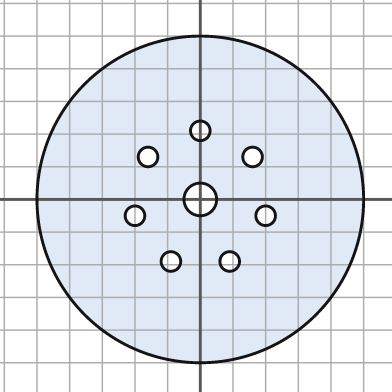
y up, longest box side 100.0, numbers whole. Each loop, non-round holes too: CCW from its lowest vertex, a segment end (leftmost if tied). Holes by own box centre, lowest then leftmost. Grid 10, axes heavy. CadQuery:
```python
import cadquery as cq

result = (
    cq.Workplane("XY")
    .moveTo(0.0, 0.0)
    .circle(50.0)
    .moveTo(-9.0, -19.0)
    .circle(3.0)
    .moveTo(9.0, -19.0)
    .circle(3.0)
    .moveTo(-20.0, -5.0)
    .circle(3.0)
    .moveTo(20.0, -5.0)
    .circle(3.0)
    .moveTo(0.0, 0.0)
    .circle(5.0)
    .moveTo(-16.0, 13.0)
    .circle(3.0)
    .moveTo(16.0, 13.0)
    .circle(3.0)
    .moveTo(0.0, 21.0)
    .circle(3.0)
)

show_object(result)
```